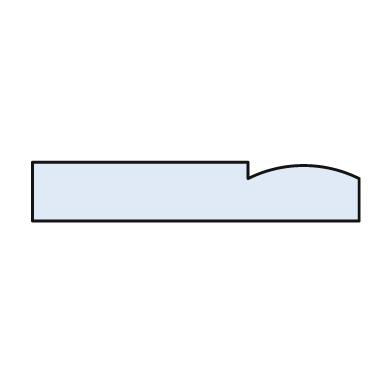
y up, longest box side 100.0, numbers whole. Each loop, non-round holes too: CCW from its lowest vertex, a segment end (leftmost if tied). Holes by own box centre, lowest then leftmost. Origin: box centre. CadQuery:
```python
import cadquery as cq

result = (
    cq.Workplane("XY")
    .moveTo(-50.0, -9.0)
    .lineTo(50.0, -9.0)
    .lineTo(50.0, 4.0)
    .threePointArc((33.0, 8.0), (16.0, 4.0))
    .lineTo(16.0, 9.0)
    .lineTo(-50.0, 9.0)
    .close()
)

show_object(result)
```